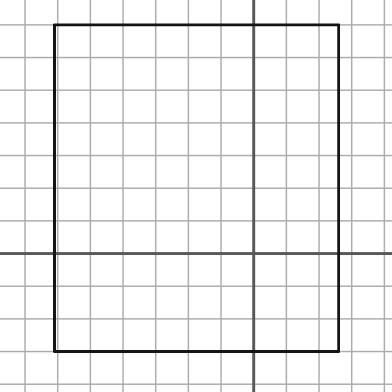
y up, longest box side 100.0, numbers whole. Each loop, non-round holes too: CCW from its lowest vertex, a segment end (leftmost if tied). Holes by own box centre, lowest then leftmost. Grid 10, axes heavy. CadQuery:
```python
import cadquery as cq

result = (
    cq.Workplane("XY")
    .moveTo(-61.0, -30.0)
    .lineTo(26.0, -30.0)
    .lineTo(26.0, 70.0)
    .lineTo(-61.0, 70.0)
    .close()
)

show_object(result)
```